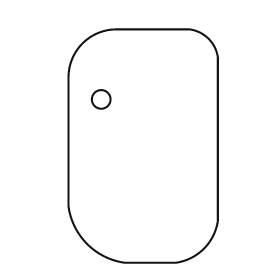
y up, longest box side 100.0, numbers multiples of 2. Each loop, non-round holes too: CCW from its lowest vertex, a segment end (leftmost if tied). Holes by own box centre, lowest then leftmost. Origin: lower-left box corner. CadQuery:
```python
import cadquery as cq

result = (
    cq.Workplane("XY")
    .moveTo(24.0, 0.0)
    .lineTo(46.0, 0.0)
    .threePointArc((58.0, 6.0), (64.0, 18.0))
    .lineTo(64.0, 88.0)
    .threePointArc((60.0, 96.0), (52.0, 100.0))
    .lineTo(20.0, 100.0)
    .threePointArc((6.0, 94.0), (0.0, 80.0))
    .lineTo(0.0, 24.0)
    .threePointArc((8.0, 8.0), (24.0, 0.0))
    .close()
    .moveTo(14.0, 70.0)
    .circle(4.0)
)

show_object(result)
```